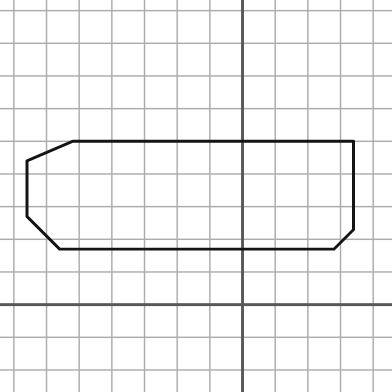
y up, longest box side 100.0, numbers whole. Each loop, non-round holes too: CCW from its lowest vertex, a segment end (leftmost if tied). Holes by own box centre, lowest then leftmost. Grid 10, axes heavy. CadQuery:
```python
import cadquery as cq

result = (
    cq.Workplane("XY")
    .moveTo(-56.0, 17.0)
    .lineTo(28.0, 17.0)
    .lineTo(34.0, 23.0)
    .lineTo(34.0, 50.0)
    .lineTo(-52.0, 50.0)
    .lineTo(-66.0, 44.0)
    .lineTo(-66.0, 27.0)
    .close()
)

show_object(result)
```